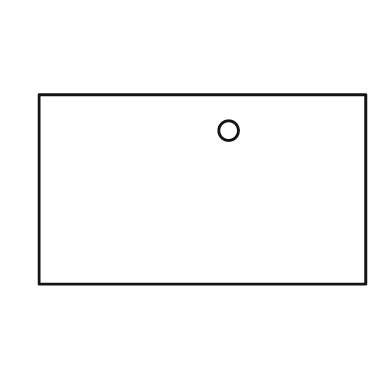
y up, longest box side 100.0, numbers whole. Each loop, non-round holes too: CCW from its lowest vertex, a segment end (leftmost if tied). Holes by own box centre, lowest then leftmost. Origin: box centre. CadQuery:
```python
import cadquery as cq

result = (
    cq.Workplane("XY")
    .moveTo(-50.0, -29.0)
    .lineTo(50.0, -29.0)
    .lineTo(50.0, 29.0)
    .lineTo(-50.0, 29.0)
    .close()
    .moveTo(8.0, 18.0)
    .circle(3.0)
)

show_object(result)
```